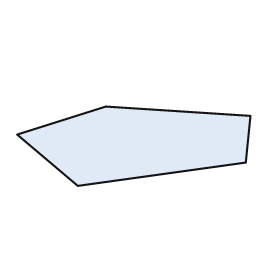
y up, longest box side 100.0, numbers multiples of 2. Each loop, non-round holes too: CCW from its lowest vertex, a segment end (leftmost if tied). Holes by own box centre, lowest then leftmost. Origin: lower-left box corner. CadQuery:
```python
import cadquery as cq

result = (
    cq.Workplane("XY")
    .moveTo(26.0, 0.0)
    .lineTo(98.0, 10.0)
    .lineTo(100.0, 30.0)
    .lineTo(38.0, 34.0)
    .lineTo(0.0, 22.0)
    .close()
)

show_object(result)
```